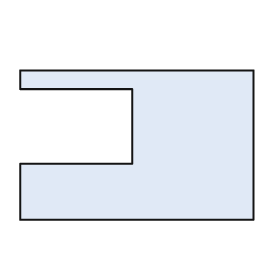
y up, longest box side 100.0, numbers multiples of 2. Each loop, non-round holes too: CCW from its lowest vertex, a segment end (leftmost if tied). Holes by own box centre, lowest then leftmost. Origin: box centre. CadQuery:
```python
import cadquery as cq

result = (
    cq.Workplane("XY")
    .moveTo(-50.0, -32.0)
    .lineTo(50.0, -32.0)
    .lineTo(50.0, 32.0)
    .lineTo(-50.0, 32.0)
    .lineTo(-50.0, 24.0)
    .lineTo(-2.0, 24.0)
    .lineTo(-2.0, -8.0)
    .lineTo(-50.0, -8.0)
    .close()
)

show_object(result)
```